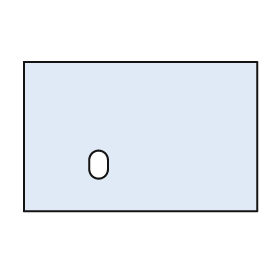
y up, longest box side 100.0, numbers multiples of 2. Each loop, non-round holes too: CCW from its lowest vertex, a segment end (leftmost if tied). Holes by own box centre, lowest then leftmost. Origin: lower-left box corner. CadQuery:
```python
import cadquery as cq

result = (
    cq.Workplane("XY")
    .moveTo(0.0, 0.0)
    .lineTo(100.0, 0.0)
    .lineTo(100.0, 64.0)
    .lineTo(0.0, 64.0)
    .close()
    .moveTo(28.0, 18.0)
    .threePointArc((32.0, 14.0), (36.0, 18.0))
    .lineTo(36.0, 22.0)
    .threePointArc((32.0, 26.0), (28.0, 22.0))
    .close()
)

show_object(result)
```